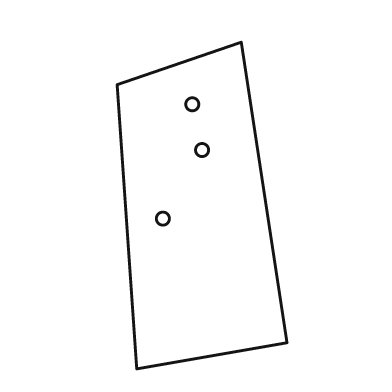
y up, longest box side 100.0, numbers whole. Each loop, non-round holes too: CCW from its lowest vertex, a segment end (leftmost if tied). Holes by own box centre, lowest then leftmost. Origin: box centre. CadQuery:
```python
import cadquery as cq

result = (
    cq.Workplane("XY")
    .moveTo(-20.0, -50.0)
    .lineTo(26.0, -42.0)
    .lineTo(12.0, 50.0)
    .lineTo(-26.0, 37.0)
    .close()
    .moveTo(-12.0, -4.0)
    .circle(2.0)
    .moveTo(0.0, 17.0)
    .circle(2.0)
    .moveTo(-3.0, 31.0)
    .circle(2.0)
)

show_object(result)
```